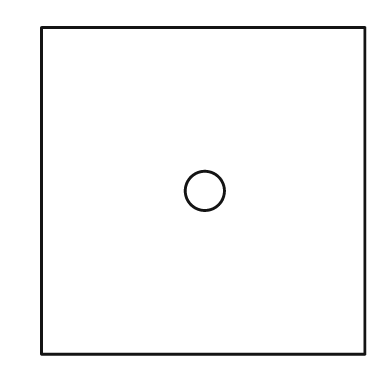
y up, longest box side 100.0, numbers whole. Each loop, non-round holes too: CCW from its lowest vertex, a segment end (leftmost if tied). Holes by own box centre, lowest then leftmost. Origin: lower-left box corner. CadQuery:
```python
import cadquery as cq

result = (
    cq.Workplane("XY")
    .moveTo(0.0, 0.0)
    .lineTo(99.0, 0.0)
    .lineTo(99.0, 100.0)
    .lineTo(0.0, 100.0)
    .close()
    .moveTo(50.0, 50.0)
    .circle(6.0)
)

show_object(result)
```